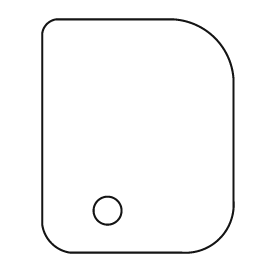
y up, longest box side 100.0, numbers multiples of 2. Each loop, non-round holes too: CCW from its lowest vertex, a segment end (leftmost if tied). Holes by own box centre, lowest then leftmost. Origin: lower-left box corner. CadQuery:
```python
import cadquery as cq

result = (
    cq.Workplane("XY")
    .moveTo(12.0, 0.0)
    .lineTo(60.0, 0.0)
    .threePointArc((76.0, 6.0), (82.0, 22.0))
    .lineTo(82.0, 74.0)
    .threePointArc((74.0, 92.0), (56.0, 100.0))
    .lineTo(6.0, 100.0)
    .threePointArc((2.0, 98.0), (0.0, 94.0))
    .lineTo(0.0, 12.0)
    .threePointArc((4.0, 4.0), (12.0, 0.0))
    .close()
    .moveTo(28.0, 18.0)
    .circle(6.0)
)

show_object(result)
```